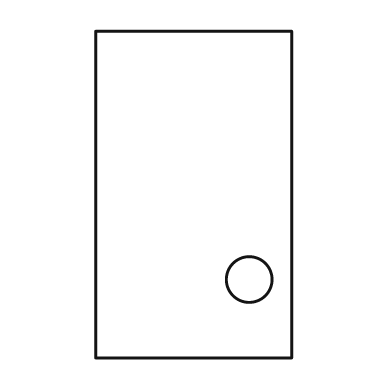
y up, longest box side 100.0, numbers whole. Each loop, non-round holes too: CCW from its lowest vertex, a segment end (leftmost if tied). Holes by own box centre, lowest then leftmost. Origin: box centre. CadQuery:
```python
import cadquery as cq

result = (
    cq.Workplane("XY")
    .moveTo(-30.0, -50.0)
    .lineTo(30.0, -50.0)
    .lineTo(30.0, 50.0)
    .lineTo(-30.0, 50.0)
    .close()
    .moveTo(17.0, -26.0)
    .circle(7.0)
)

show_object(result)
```